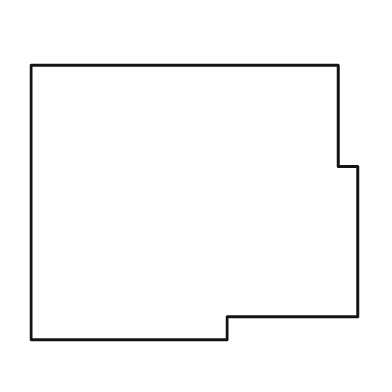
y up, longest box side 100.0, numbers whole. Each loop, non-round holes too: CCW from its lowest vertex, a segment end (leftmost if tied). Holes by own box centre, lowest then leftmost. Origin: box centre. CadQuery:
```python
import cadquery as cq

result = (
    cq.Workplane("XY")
    .moveTo(-50.0, -42.0)
    .lineTo(10.0, -42.0)
    .lineTo(10.0, -35.0)
    .lineTo(50.0, -35.0)
    .lineTo(50.0, 11.0)
    .lineTo(44.0, 11.0)
    .lineTo(44.0, 42.0)
    .lineTo(-50.0, 42.0)
    .close()
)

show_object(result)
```